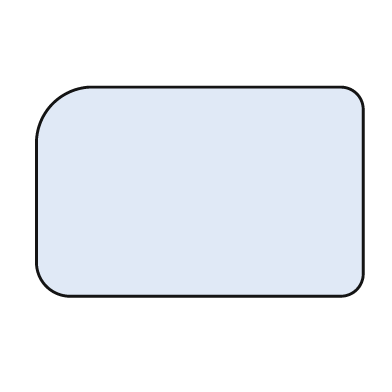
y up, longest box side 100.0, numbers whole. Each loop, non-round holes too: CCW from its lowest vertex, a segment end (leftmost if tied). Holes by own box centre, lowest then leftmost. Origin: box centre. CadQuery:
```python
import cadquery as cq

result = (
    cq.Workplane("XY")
    .moveTo(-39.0, -32.0)
    .lineTo(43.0, -32.0)
    .threePointArc((48.0, -30.0), (50.0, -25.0))
    .lineTo(50.0, 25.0)
    .threePointArc((48.0, 30.0), (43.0, 32.0))
    .lineTo(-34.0, 32.0)
    .threePointArc((-45.0, 27.0), (-50.0, 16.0))
    .lineTo(-50.0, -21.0)
    .threePointArc((-47.0, -29.0), (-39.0, -32.0))
    .close()
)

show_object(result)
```